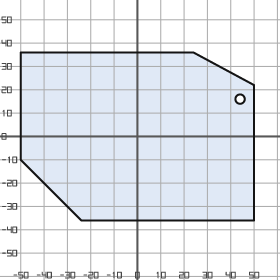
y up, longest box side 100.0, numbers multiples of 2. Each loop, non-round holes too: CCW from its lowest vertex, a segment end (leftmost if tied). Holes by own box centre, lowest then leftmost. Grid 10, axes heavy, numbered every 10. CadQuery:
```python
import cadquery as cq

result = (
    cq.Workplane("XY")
    .moveTo(-24.0, -36.0)
    .lineTo(50.0, -36.0)
    .lineTo(50.0, 22.0)
    .lineTo(24.0, 36.0)
    .lineTo(-50.0, 36.0)
    .lineTo(-50.0, -10.0)
    .close()
    .moveTo(44.0, 16.0)
    .circle(2.0)
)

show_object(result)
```